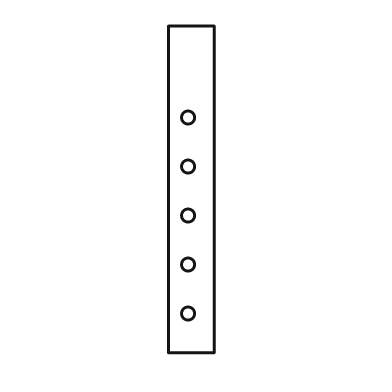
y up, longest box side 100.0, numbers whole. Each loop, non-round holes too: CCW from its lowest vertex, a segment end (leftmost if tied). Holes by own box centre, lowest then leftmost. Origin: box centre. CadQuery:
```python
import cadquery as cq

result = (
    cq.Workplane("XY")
    .moveTo(-7.0, -50.0)
    .lineTo(7.0, -50.0)
    .lineTo(7.0, 50.0)
    .lineTo(-7.0, 50.0)
    .close()
    .moveTo(-1.0, -38.0)
    .circle(2.0)
    .moveTo(-1.0, -23.0)
    .circle(2.0)
    .moveTo(-1.0, -8.0)
    .circle(2.0)
    .moveTo(-1.0, 7.0)
    .circle(2.0)
    .moveTo(-1.0, 22.0)
    .circle(2.0)
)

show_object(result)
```